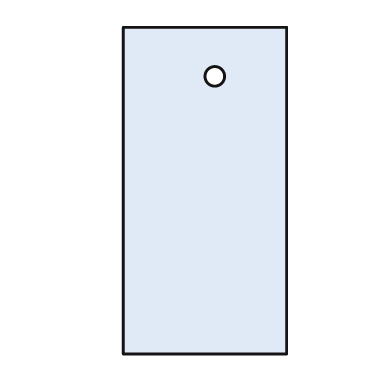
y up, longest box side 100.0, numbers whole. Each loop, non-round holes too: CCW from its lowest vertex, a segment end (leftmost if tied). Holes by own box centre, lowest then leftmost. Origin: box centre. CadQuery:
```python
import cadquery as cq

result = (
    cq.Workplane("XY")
    .moveTo(-25.0, -50.0)
    .lineTo(25.0, -50.0)
    .lineTo(25.0, 50.0)
    .lineTo(-25.0, 50.0)
    .close()
    .moveTo(3.0, 35.0)
    .circle(3.0)
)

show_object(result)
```